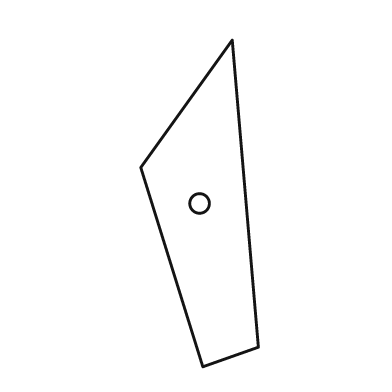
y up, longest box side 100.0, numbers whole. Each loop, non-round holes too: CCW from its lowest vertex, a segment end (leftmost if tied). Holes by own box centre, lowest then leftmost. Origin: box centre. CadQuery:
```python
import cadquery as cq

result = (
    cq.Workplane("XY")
    .moveTo(1.0, -50.0)
    .lineTo(18.0, -44.0)
    .lineTo(10.0, 50.0)
    .lineTo(-18.0, 11.0)
    .close()
    .moveTo(0.0, 0.0)
    .circle(3.0)
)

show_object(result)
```